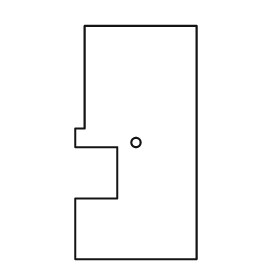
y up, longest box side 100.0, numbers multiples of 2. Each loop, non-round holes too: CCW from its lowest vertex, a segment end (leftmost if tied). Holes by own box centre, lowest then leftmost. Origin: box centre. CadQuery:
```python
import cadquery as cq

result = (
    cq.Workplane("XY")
    .moveTo(-26.0, -50.0)
    .lineTo(26.0, -50.0)
    .lineTo(26.0, 50.0)
    .lineTo(-22.0, 50.0)
    .lineTo(-22.0, 6.0)
    .lineTo(-26.0, 6.0)
    .lineTo(-26.0, -2.0)
    .lineTo(-8.0, -2.0)
    .lineTo(-8.0, -24.0)
    .lineTo(-26.0, -24.0)
    .close()
    .moveTo(0.0, 0.0)
    .circle(2.0)
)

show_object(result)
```